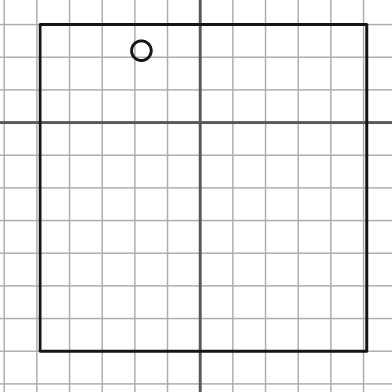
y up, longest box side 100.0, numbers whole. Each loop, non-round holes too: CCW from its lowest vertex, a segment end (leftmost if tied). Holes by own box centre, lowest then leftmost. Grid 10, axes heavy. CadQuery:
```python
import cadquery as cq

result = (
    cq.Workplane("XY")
    .moveTo(-49.0, -70.0)
    .lineTo(51.0, -70.0)
    .lineTo(51.0, 30.0)
    .lineTo(-49.0, 30.0)
    .close()
    .moveTo(-18.0, 22.0)
    .circle(3.0)
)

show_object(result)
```